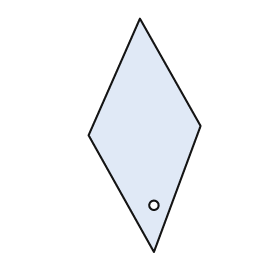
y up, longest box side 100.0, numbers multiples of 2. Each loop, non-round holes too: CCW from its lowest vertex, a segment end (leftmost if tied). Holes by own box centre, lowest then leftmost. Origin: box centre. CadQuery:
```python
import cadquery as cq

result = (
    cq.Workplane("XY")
    .moveTo(4.0, -50.0)
    .lineTo(24.0, 4.0)
    .lineTo(-2.0, 50.0)
    .lineTo(-24.0, 0.0)
    .close()
    .moveTo(4.0, -30.0)
    .circle(2.0)
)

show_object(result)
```